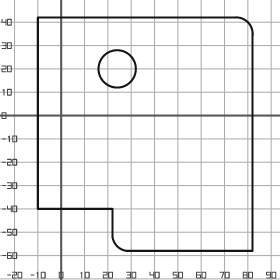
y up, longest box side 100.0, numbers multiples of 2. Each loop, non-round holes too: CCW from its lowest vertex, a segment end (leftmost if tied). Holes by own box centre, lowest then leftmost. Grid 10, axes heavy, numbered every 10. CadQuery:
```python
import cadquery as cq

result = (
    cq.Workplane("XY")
    .moveTo(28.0, -58.0)
    .lineTo(82.0, -58.0)
    .lineTo(82.0, 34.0)
    .threePointArc((80.0, 40.0), (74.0, 42.0))
    .lineTo(-10.0, 42.0)
    .lineTo(-10.0, -40.0)
    .lineTo(22.0, -40.0)
    .lineTo(22.0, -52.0)
    .threePointArc((24.0, -56.0), (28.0, -58.0))
    .close()
    .moveTo(24.0, 20.0)
    .circle(8.0)
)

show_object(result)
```